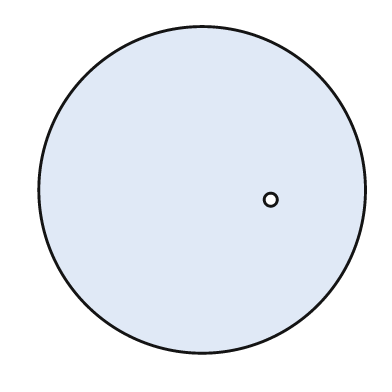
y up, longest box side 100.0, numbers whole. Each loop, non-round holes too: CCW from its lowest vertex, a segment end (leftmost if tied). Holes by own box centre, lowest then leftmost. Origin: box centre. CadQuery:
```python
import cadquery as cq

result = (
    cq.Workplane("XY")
    .moveTo(0.0, 0.0)
    .circle(50.0)
    .moveTo(21.0, -3.0)
    .circle(2.0)
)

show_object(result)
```